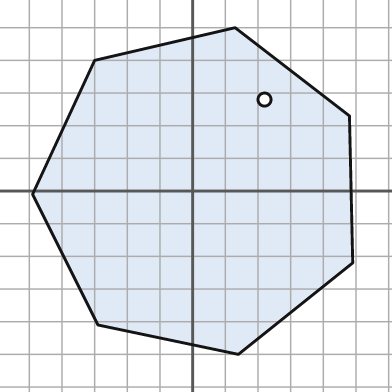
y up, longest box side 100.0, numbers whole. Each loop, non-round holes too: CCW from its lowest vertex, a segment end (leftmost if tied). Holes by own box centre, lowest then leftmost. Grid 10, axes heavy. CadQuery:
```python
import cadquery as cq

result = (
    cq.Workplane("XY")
    .moveTo(14.0, -50.0)
    .lineTo(49.0, -22.0)
    .lineTo(48.0, 23.0)
    .lineTo(13.0, 50.0)
    .lineTo(-30.0, 40.0)
    .lineTo(-49.0, -1.0)
    .lineTo(-29.0, -41.0)
    .close()
    .moveTo(22.0, 28.0)
    .circle(2.0)
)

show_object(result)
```